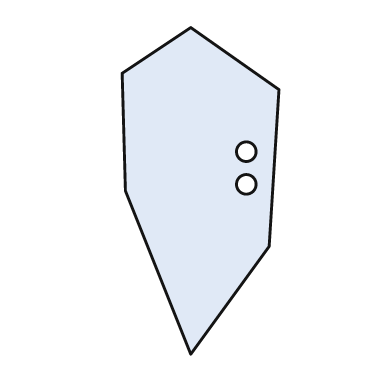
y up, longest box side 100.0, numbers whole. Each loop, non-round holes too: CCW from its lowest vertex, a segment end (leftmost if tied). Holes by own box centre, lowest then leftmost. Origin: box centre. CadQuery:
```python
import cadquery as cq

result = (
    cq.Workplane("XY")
    .moveTo(-3.0, -50.0)
    .lineTo(21.0, -17.0)
    .lineTo(24.0, 31.0)
    .lineTo(-3.0, 50.0)
    .lineTo(-24.0, 36.0)
    .lineTo(-23.0, 0.0)
    .close()
    .moveTo(14.0, 2.0)
    .circle(3.0)
    .moveTo(14.0, 12.0)
    .circle(3.0)
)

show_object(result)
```